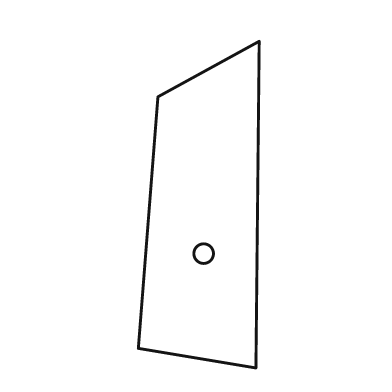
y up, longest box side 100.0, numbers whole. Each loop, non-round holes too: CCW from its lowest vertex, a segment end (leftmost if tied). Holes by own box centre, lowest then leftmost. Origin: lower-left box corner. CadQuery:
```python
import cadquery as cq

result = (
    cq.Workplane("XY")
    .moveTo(36.0, 0.0)
    .lineTo(37.0, 100.0)
    .lineTo(6.0, 83.0)
    .lineTo(0.0, 6.0)
    .close()
    .moveTo(20.0, 35.0)
    .circle(3.0)
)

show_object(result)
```